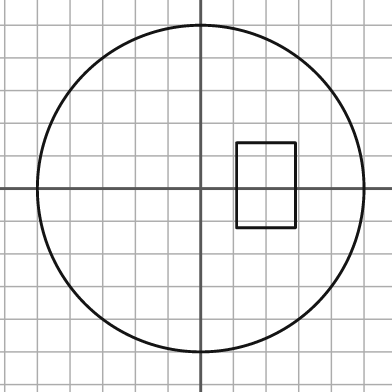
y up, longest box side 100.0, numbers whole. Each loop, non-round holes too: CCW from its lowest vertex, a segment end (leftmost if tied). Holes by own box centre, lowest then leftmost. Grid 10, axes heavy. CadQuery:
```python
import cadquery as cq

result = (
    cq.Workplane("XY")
    .moveTo(0.0, 0.0)
    .circle(50.0)
    .moveTo(11.0, -12.0)
    .lineTo(29.0, -12.0)
    .lineTo(29.0, 14.0)
    .lineTo(11.0, 14.0)
    .close()
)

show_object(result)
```